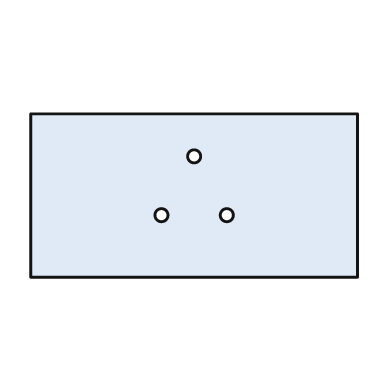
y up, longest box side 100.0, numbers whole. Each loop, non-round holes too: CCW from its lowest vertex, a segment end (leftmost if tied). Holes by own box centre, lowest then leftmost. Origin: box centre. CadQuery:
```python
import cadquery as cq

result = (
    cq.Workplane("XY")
    .moveTo(-50.0, -25.0)
    .lineTo(50.0, -25.0)
    .lineTo(50.0, 25.0)
    .lineTo(-50.0, 25.0)
    .close()
    .moveTo(-10.0, -6.0)
    .circle(2.0)
    .moveTo(10.0, -6.0)
    .circle(2.0)
    .moveTo(0.0, 12.0)
    .circle(2.0)
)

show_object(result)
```